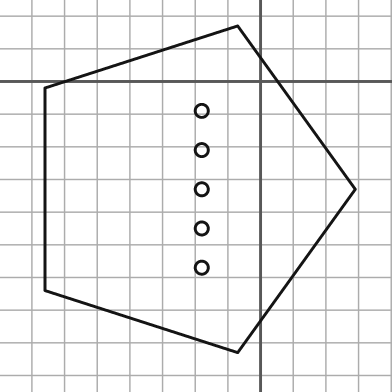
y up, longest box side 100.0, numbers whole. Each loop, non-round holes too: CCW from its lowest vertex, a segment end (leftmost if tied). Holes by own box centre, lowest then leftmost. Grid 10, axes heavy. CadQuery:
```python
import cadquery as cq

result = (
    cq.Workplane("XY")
    .moveTo(-7.0, -83.0)
    .lineTo(29.0, -33.0)
    .lineTo(-7.0, 17.0)
    .lineTo(-66.0, -2.0)
    .lineTo(-66.0, -64.0)
    .close()
    .moveTo(-18.0, -57.0)
    .circle(2.0)
    .moveTo(-18.0, -45.0)
    .circle(2.0)
    .moveTo(-18.0, -33.0)
    .circle(2.0)
    .moveTo(-18.0, -21.0)
    .circle(2.0)
    .moveTo(-18.0, -9.0)
    .circle(2.0)
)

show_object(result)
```